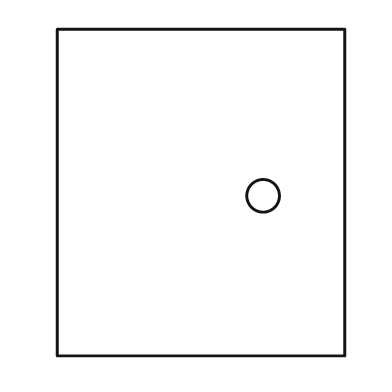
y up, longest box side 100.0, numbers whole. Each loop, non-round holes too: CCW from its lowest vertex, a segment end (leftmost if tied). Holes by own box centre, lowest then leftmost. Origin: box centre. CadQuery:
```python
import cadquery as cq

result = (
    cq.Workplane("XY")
    .moveTo(-44.0, -50.0)
    .lineTo(44.0, -50.0)
    .lineTo(44.0, 50.0)
    .lineTo(-44.0, 50.0)
    .close()
    .moveTo(19.0, -1.0)
    .circle(5.0)
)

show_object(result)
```